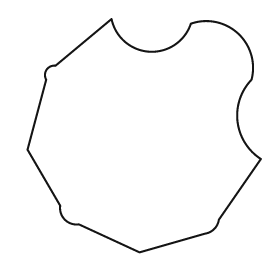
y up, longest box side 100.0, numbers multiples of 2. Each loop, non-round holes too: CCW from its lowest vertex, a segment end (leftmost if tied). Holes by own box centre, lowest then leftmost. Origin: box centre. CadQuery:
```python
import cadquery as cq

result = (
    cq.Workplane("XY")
    .moveTo(-2.0, -50.0)
    .lineTo(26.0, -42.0)
    .threePointArc((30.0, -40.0), (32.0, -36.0))
    .lineTo(50.0, -10.0)
    .threePointArc((40.0, 6.0), (46.0, 24.0))
    .threePointArc((40.0, 44.0), (20.0, 48.0))
    .threePointArc((2.0, 36.0), (-14.0, 50.0))
    .lineTo(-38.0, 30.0)
    .threePointArc((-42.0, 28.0), (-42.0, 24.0))
    .lineTo(-50.0, -6.0)
    .lineTo(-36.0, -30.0)
    .threePointArc((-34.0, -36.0), (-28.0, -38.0))
    .close()
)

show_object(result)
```